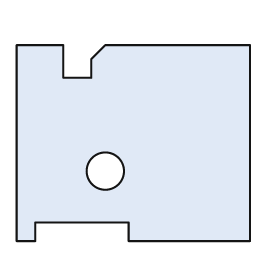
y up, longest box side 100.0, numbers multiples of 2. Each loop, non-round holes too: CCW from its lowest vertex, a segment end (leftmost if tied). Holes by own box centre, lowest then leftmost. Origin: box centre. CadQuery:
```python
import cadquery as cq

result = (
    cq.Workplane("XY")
    .moveTo(-50.0, -42.0)
    .lineTo(-42.0, -42.0)
    .lineTo(-42.0, -34.0)
    .lineTo(-2.0, -34.0)
    .lineTo(-2.0, -42.0)
    .lineTo(50.0, -42.0)
    .lineTo(50.0, 42.0)
    .lineTo(-12.0, 42.0)
    .lineTo(-18.0, 36.0)
    .lineTo(-18.0, 28.0)
    .lineTo(-30.0, 28.0)
    .lineTo(-30.0, 42.0)
    .lineTo(-50.0, 42.0)
    .close()
    .moveTo(-12.0, -12.0)
    .circle(8.0)
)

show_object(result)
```